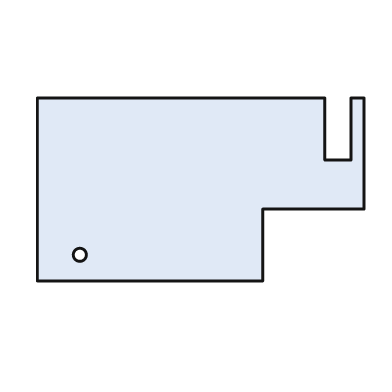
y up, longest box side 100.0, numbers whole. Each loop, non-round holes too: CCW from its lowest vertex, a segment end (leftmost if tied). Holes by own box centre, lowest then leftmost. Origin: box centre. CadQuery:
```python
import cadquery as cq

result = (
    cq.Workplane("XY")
    .moveTo(-50.0, -28.0)
    .lineTo(19.0, -28.0)
    .lineTo(19.0, -6.0)
    .lineTo(50.0, -6.0)
    .lineTo(50.0, 28.0)
    .lineTo(46.0, 28.0)
    .lineTo(46.0, 9.0)
    .lineTo(38.0, 9.0)
    .lineTo(38.0, 28.0)
    .lineTo(-50.0, 28.0)
    .close()
    .moveTo(-37.0, -20.0)
    .circle(2.0)
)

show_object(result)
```